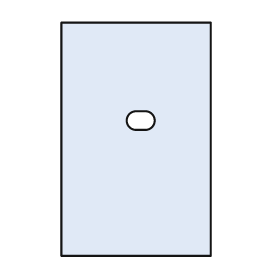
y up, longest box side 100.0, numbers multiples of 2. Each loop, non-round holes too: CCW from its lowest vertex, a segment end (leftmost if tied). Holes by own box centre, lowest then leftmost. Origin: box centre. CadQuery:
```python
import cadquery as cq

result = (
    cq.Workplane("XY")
    .moveTo(-32.0, -50.0)
    .lineTo(32.0, -50.0)
    .lineTo(32.0, 50.0)
    .lineTo(-32.0, 50.0)
    .close()
    .moveTo(0.0, 4.0)
    .lineTo(4.0, 4.0)
    .threePointArc((8.0, 8.0), (4.0, 12.0))
    .lineTo(0.0, 12.0)
    .threePointArc((-4.0, 8.0), (0.0, 4.0))
    .close()
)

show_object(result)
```